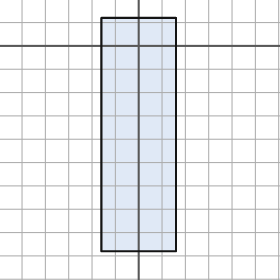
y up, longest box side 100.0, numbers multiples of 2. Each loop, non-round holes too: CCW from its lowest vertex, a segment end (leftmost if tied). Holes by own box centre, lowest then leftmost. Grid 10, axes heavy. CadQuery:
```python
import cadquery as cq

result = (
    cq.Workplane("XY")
    .moveTo(-16.0, -88.0)
    .lineTo(16.0, -88.0)
    .lineTo(16.0, 12.0)
    .lineTo(-16.0, 12.0)
    .close()
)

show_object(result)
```